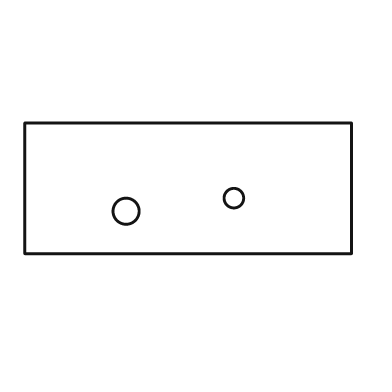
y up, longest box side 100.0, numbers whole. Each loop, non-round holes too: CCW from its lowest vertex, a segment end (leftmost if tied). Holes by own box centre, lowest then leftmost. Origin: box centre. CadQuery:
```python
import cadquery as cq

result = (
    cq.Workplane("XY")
    .moveTo(-50.0, -20.0)
    .lineTo(50.0, -20.0)
    .lineTo(50.0, 20.0)
    .lineTo(-50.0, 20.0)
    .close()
    .moveTo(-19.0, -7.0)
    .circle(4.0)
    .moveTo(14.0, -3.0)
    .circle(3.0)
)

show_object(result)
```